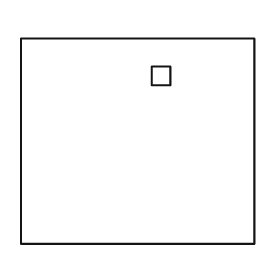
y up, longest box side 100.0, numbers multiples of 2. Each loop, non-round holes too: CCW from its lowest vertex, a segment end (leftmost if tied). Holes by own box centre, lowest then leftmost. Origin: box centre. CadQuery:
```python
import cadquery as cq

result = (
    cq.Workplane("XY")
    .moveTo(-50.0, -44.0)
    .lineTo(50.0, -44.0)
    .lineTo(50.0, 44.0)
    .lineTo(-50.0, 44.0)
    .close()
    .moveTo(6.0, 24.0)
    .lineTo(14.0, 24.0)
    .lineTo(14.0, 32.0)
    .lineTo(6.0, 32.0)
    .close()
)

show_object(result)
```